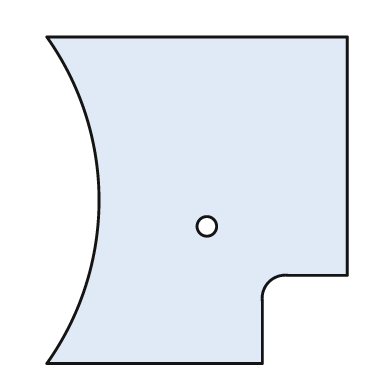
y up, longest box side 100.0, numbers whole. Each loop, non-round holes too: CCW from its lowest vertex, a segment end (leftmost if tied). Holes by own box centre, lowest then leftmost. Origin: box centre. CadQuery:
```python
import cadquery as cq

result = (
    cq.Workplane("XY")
    .moveTo(-46.0, -50.0)
    .lineTo(20.0, -50.0)
    .lineTo(20.0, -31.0)
    .threePointArc((22.0, -25.0), (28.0, -23.0))
    .lineTo(46.0, -23.0)
    .lineTo(46.0, 50.0)
    .lineTo(-46.0, 50.0)
    .threePointArc((-30.0, 0.0), (-46.0, -50.0))
    .close()
    .moveTo(3.0, -8.0)
    .circle(3.0)
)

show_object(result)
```